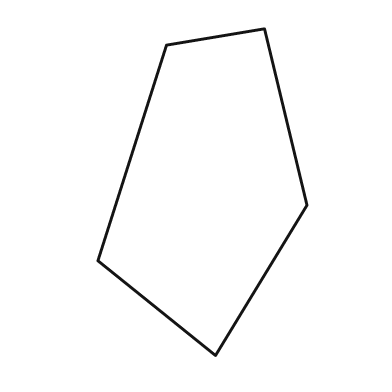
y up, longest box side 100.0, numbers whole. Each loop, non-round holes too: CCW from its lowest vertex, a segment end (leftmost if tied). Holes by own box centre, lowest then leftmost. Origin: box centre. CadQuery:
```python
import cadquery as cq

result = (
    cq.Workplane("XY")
    .moveTo(4.0, -50.0)
    .lineTo(32.0, -4.0)
    .lineTo(19.0, 50.0)
    .lineTo(-11.0, 45.0)
    .lineTo(-32.0, -21.0)
    .close()
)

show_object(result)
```